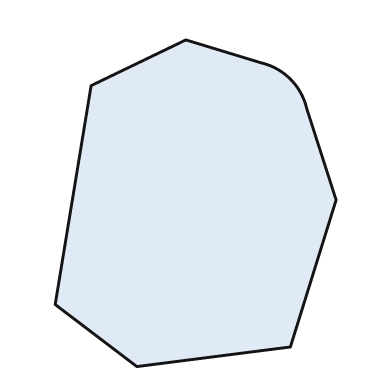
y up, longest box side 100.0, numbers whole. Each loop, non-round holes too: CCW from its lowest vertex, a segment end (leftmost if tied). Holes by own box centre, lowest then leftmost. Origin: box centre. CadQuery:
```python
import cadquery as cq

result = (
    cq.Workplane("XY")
    .moveTo(-18.0, -50.0)
    .lineTo(29.0, -44.0)
    .lineTo(43.0, 1.0)
    .lineTo(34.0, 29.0)
    .threePointArc((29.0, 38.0), (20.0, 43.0))
    .lineTo(-3.0, 50.0)
    .lineTo(-32.0, 36.0)
    .lineTo(-43.0, -31.0)
    .close()
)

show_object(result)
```